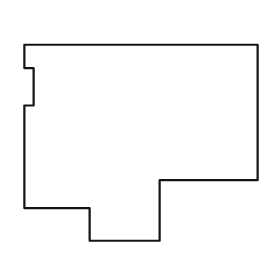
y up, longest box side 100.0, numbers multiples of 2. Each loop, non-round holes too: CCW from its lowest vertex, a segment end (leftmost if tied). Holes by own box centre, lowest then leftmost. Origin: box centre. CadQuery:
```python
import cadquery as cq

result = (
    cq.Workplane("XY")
    .moveTo(-22.0, -42.0)
    .lineTo(8.0, -42.0)
    .lineTo(8.0, -16.0)
    .lineTo(50.0, -16.0)
    .lineTo(50.0, 42.0)
    .lineTo(-50.0, 42.0)
    .lineTo(-50.0, 32.0)
    .lineTo(-46.0, 32.0)
    .lineTo(-46.0, 16.0)
    .lineTo(-50.0, 16.0)
    .lineTo(-50.0, -28.0)
    .lineTo(-22.0, -28.0)
    .close()
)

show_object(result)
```